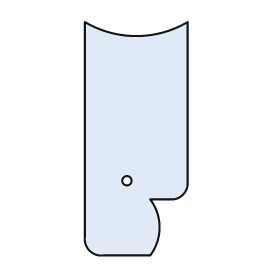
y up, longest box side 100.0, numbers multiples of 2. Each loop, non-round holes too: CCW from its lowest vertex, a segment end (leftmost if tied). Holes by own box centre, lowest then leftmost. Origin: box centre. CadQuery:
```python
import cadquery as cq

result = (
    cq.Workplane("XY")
    .moveTo(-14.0, -50.0)
    .lineTo(6.0, -50.0)
    .threePointArc((10.0, -38.0), (6.0, -26.0))
    .lineTo(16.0, -26.0)
    .threePointArc((20.0, -24.0), (22.0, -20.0))
    .lineTo(22.0, 50.0)
    .threePointArc((0.0, 44.0), (-22.0, 50.0))
    .lineTo(-22.0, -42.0)
    .threePointArc((-20.0, -48.0), (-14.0, -50.0))
    .close()
    .moveTo(-4.0, -18.0)
    .circle(2.0)
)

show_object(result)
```